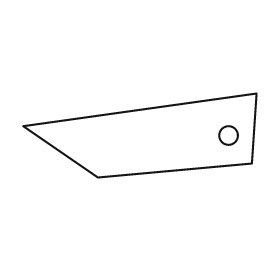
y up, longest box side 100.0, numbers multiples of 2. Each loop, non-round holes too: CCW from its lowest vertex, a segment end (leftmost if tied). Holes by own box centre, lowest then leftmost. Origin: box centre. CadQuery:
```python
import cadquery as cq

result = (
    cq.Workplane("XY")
    .moveTo(-18.0, -18.0)
    .lineTo(48.0, -12.0)
    .lineTo(50.0, 18.0)
    .lineTo(-50.0, 4.0)
    .close()
    .moveTo(38.0, 0.0)
    .circle(4.0)
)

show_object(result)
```